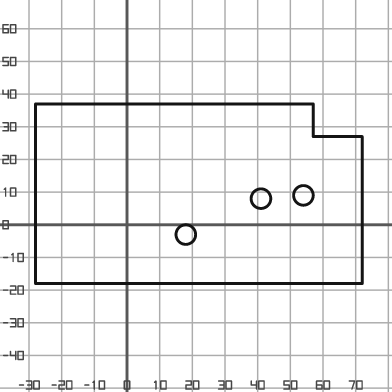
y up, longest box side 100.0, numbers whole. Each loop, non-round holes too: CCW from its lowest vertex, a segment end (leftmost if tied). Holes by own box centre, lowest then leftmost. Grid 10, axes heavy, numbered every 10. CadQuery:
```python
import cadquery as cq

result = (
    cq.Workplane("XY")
    .moveTo(-28.0, -18.0)
    .lineTo(72.0, -18.0)
    .lineTo(72.0, 27.0)
    .lineTo(57.0, 27.0)
    .lineTo(57.0, 37.0)
    .lineTo(-28.0, 37.0)
    .close()
    .moveTo(18.0, -3.0)
    .circle(3.0)
    .moveTo(41.0, 8.0)
    .circle(3.0)
    .moveTo(54.0, 9.0)
    .circle(3.0)
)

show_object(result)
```